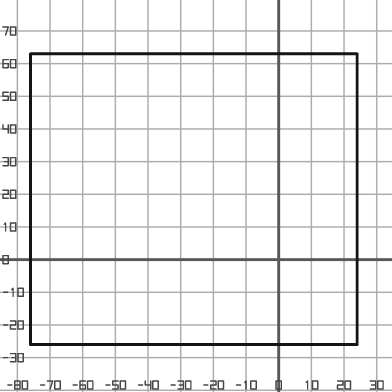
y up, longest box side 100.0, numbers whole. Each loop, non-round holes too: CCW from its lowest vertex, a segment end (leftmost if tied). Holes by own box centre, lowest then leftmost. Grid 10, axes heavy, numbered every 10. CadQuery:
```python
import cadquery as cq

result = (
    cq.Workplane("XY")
    .moveTo(-76.0, -26.0)
    .lineTo(24.0, -26.0)
    .lineTo(24.0, 63.0)
    .lineTo(-76.0, 63.0)
    .close()
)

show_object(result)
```